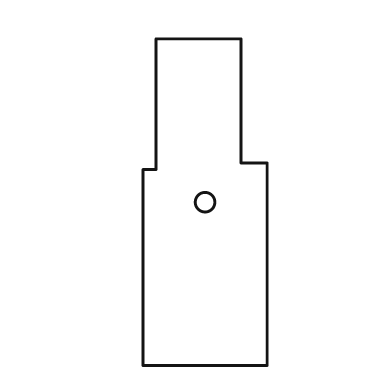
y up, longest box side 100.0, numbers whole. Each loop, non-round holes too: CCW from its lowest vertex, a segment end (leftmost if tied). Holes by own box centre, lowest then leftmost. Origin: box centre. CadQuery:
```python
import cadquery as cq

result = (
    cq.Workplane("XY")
    .moveTo(-19.0, -50.0)
    .lineTo(19.0, -50.0)
    .lineTo(19.0, 12.0)
    .lineTo(11.0, 12.0)
    .lineTo(11.0, 50.0)
    .lineTo(-15.0, 50.0)
    .lineTo(-15.0, 10.0)
    .lineTo(-19.0, 10.0)
    .close()
    .moveTo(0.0, 0.0)
    .circle(3.0)
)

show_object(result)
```